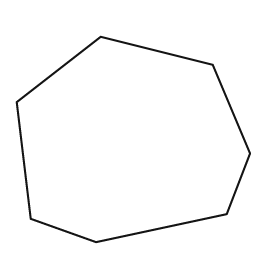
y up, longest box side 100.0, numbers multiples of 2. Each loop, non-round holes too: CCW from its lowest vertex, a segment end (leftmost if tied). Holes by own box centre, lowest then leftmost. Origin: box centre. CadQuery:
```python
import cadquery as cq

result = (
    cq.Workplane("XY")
    .moveTo(-16.0, -44.0)
    .lineTo(40.0, -32.0)
    .lineTo(50.0, -6.0)
    .lineTo(34.0, 32.0)
    .lineTo(-14.0, 44.0)
    .lineTo(-50.0, 16.0)
    .lineTo(-44.0, -34.0)
    .close()
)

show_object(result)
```